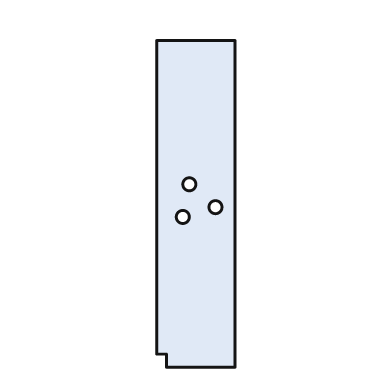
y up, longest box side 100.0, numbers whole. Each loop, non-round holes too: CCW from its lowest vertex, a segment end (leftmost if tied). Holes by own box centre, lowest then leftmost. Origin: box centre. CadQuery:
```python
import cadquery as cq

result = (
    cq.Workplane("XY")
    .moveTo(-9.0, -50.0)
    .lineTo(12.0, -50.0)
    .lineTo(12.0, 50.0)
    .lineTo(-12.0, 50.0)
    .lineTo(-12.0, -46.0)
    .lineTo(-9.0, -46.0)
    .close()
    .moveTo(-4.0, -4.0)
    .circle(2.0)
    .moveTo(6.0, -1.0)
    .circle(2.0)
    .moveTo(-2.0, 6.0)
    .circle(2.0)
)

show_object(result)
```